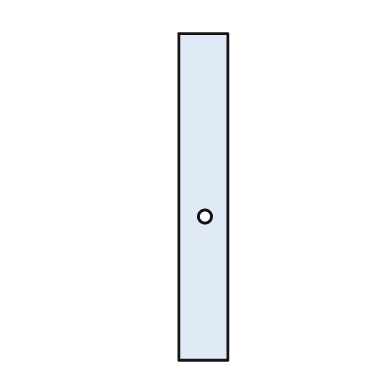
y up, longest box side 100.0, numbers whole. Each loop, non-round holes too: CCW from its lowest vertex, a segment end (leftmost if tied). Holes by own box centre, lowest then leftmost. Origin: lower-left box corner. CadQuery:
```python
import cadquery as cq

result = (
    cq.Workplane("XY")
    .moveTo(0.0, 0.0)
    .lineTo(15.0, 0.0)
    .lineTo(15.0, 100.0)
    .lineTo(0.0, 100.0)
    .close()
    .moveTo(8.0, 44.0)
    .circle(2.0)
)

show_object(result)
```